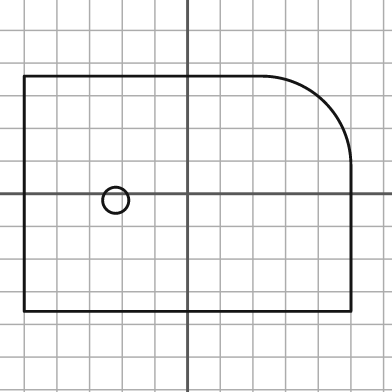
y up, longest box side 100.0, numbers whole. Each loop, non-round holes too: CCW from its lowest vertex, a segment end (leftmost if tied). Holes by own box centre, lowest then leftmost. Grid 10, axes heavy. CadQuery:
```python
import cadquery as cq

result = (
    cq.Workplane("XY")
    .moveTo(-50.0, -36.0)
    .lineTo(50.0, -36.0)
    .lineTo(50.0, 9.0)
    .threePointArc((42.0, 28.0), (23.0, 36.0))
    .lineTo(-50.0, 36.0)
    .close()
    .moveTo(-22.0, -2.0)
    .circle(4.0)
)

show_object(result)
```